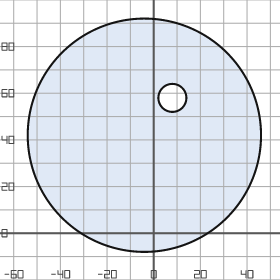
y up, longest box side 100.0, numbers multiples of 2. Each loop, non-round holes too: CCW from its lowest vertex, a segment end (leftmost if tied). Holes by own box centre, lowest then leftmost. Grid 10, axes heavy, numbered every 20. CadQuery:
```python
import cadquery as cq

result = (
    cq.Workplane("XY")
    .moveTo(-4.0, 42.0)
    .circle(50.0)
    .moveTo(8.0, 58.0)
    .circle(6.0)
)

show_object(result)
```